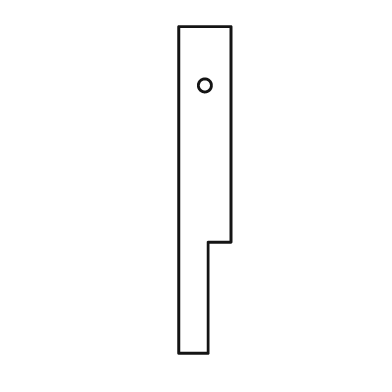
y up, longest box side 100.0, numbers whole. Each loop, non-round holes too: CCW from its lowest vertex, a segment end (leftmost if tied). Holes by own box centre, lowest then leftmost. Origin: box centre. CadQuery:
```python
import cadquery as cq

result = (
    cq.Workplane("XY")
    .moveTo(-8.0, -50.0)
    .lineTo(1.0, -50.0)
    .lineTo(1.0, -16.0)
    .lineTo(8.0, -16.0)
    .lineTo(8.0, 50.0)
    .lineTo(-8.0, 50.0)
    .close()
    .moveTo(0.0, 32.0)
    .circle(2.0)
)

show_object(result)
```